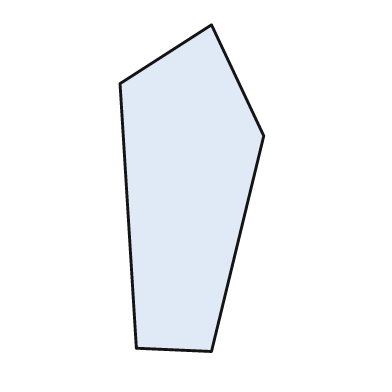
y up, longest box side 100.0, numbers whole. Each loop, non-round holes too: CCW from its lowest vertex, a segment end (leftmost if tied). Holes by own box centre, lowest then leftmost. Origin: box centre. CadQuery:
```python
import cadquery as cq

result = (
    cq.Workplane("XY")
    .moveTo(6.0, -50.0)
    .lineTo(22.0, 16.0)
    .lineTo(6.0, 50.0)
    .lineTo(-22.0, 32.0)
    .lineTo(-17.0, -49.0)
    .close()
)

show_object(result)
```